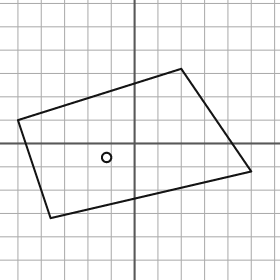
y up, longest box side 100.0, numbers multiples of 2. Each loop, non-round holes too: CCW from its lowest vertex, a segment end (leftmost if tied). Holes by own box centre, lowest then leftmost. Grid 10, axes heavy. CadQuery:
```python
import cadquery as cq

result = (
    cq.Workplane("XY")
    .moveTo(-36.0, -32.0)
    .lineTo(50.0, -12.0)
    .lineTo(20.0, 32.0)
    .lineTo(-50.0, 10.0)
    .close()
    .moveTo(-12.0, -6.0)
    .circle(2.0)
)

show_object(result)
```